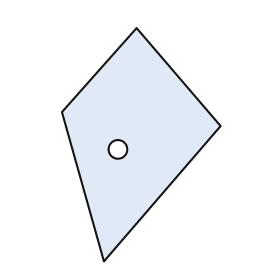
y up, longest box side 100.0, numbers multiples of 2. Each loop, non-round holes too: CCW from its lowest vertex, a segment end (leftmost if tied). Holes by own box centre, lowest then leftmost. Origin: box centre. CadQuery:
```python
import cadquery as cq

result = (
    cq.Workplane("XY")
    .moveTo(-16.0, -50.0)
    .lineTo(34.0, 8.0)
    .lineTo(-2.0, 50.0)
    .lineTo(-34.0, 14.0)
    .close()
    .moveTo(-10.0, -2.0)
    .circle(4.0)
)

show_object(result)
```